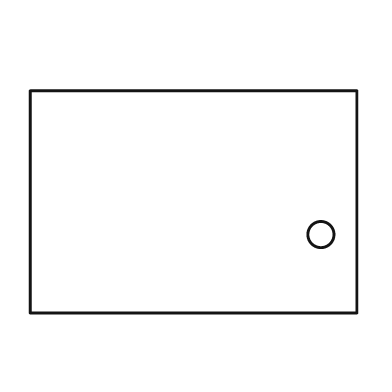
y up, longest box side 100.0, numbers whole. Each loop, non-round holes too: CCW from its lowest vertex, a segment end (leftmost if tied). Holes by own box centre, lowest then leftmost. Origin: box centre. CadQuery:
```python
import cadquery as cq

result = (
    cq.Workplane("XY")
    .moveTo(-50.0, -34.0)
    .lineTo(50.0, -34.0)
    .lineTo(50.0, 34.0)
    .lineTo(-50.0, 34.0)
    .close()
    .moveTo(39.0, -10.0)
    .circle(4.0)
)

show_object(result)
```